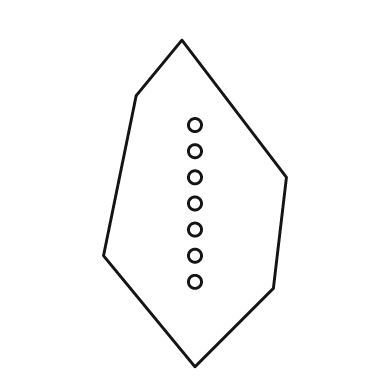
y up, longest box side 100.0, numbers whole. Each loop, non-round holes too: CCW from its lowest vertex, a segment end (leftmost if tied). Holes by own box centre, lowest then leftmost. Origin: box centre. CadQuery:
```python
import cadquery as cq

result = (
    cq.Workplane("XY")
    .moveTo(0.0, -50.0)
    .lineTo(24.0, -26.0)
    .lineTo(28.0, 8.0)
    .lineTo(-4.0, 50.0)
    .lineTo(-18.0, 33.0)
    .lineTo(-28.0, -16.0)
    .close()
    .moveTo(0.0, -24.0)
    .circle(2.0)
    .moveTo(0.0, -16.0)
    .circle(2.0)
    .moveTo(0.0, -8.0)
    .circle(2.0)
    .moveTo(0.0, 0.0)
    .circle(2.0)
    .moveTo(0.0, 8.0)
    .circle(2.0)
    .moveTo(0.0, 16.0)
    .circle(2.0)
    .moveTo(0.0, 24.0)
    .circle(2.0)
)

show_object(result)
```